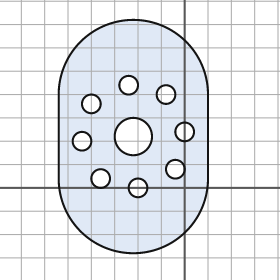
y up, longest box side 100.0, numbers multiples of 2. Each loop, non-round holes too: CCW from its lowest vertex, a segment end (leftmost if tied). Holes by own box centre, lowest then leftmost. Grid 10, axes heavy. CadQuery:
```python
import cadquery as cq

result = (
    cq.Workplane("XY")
    .moveTo(-54.0, 4.0)
    .threePointArc((-22.0, -28.0), (10.0, 4.0))
    .lineTo(10.0, 40.0)
    .threePointArc((-22.0, 72.0), (-54.0, 40.0))
    .close()
    .moveTo(-20.0, 0.0)
    .circle(4.0)
    .moveTo(-36.0, 4.0)
    .circle(4.0)
    .moveTo(-4.0, 8.0)
    .circle(4.0)
    .moveTo(-44.0, 20.0)
    .circle(4.0)
    .moveTo(-22.0, 22.0)
    .circle(8.0)
    .moveTo(0.0, 24.0)
    .circle(4.0)
    .moveTo(-40.0, 36.0)
    .circle(4.0)
    .moveTo(-8.0, 40.0)
    .circle(4.0)
    .moveTo(-24.0, 44.0)
    .circle(4.0)
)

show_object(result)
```